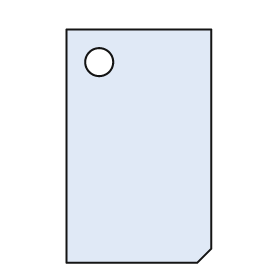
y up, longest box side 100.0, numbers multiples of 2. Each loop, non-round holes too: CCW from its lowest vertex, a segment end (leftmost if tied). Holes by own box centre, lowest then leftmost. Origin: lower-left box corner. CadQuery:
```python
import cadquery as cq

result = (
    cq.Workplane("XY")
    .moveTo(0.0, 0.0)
    .lineTo(56.0, 0.0)
    .lineTo(62.0, 6.0)
    .lineTo(62.0, 100.0)
    .lineTo(0.0, 100.0)
    .close()
    .moveTo(14.0, 86.0)
    .circle(6.0)
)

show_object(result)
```